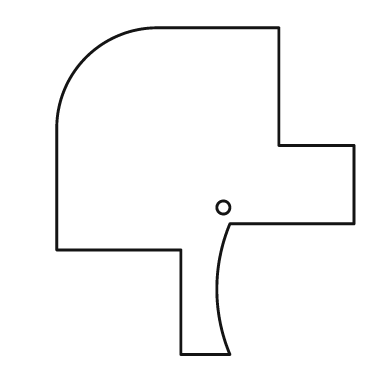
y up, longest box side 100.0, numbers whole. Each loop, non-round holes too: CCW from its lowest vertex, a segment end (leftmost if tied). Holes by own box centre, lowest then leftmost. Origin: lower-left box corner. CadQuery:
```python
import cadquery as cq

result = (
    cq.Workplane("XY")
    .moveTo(38.0, 0.0)
    .lineTo(53.0, 0.0)
    .threePointArc((49.0, 20.0), (53.0, 40.0))
    .lineTo(91.0, 40.0)
    .lineTo(91.0, 64.0)
    .lineTo(68.0, 64.0)
    .lineTo(68.0, 100.0)
    .lineTo(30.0, 100.0)
    .threePointArc((9.0, 91.0), (0.0, 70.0))
    .lineTo(0.0, 32.0)
    .lineTo(38.0, 32.0)
    .close()
    .moveTo(51.0, 45.0)
    .circle(2.0)
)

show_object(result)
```